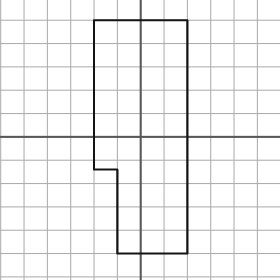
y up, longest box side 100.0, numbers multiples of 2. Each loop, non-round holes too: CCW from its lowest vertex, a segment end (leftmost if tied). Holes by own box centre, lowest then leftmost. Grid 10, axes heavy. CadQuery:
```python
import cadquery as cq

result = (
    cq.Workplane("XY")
    .moveTo(-10.0, -50.0)
    .lineTo(20.0, -50.0)
    .lineTo(20.0, 50.0)
    .lineTo(-20.0, 50.0)
    .lineTo(-20.0, -14.0)
    .lineTo(-10.0, -14.0)
    .close()
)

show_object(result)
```